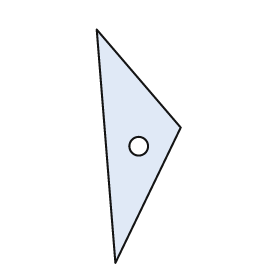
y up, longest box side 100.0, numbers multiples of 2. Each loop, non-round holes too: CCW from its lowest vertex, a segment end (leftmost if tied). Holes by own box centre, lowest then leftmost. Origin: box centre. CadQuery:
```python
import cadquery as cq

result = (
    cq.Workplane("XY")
    .moveTo(-10.0, -50.0)
    .lineTo(18.0, 8.0)
    .lineTo(-18.0, 50.0)
    .close()
    .moveTo(0.0, 0.0)
    .circle(4.0)
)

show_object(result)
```